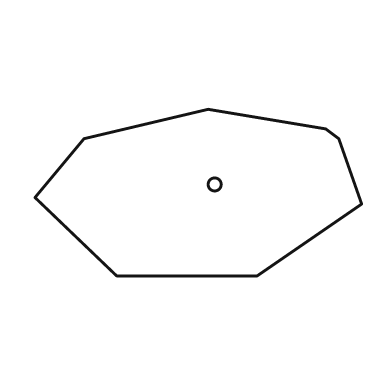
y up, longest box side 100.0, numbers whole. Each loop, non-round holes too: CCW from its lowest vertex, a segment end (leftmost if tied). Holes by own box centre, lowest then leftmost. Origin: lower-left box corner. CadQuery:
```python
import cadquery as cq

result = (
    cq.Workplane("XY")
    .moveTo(25.0, 0.0)
    .lineTo(68.0, 0.0)
    .lineTo(100.0, 22.0)
    .lineTo(93.0, 42.0)
    .lineTo(89.0, 45.0)
    .lineTo(53.0, 51.0)
    .lineTo(15.0, 42.0)
    .lineTo(0.0, 24.0)
    .close()
    .moveTo(55.0, 28.0)
    .circle(2.0)
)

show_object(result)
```